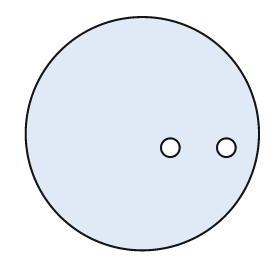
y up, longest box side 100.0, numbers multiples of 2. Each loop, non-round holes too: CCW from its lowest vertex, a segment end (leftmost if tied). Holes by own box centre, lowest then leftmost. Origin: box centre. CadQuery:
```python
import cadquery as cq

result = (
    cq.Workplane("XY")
    .moveTo(0.0, 0.0)
    .circle(50.0)
    .moveTo(12.0, -6.0)
    .circle(4.0)
    .moveTo(36.0, -6.0)
    .circle(4.0)
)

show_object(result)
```